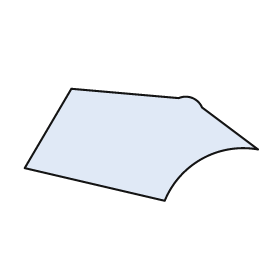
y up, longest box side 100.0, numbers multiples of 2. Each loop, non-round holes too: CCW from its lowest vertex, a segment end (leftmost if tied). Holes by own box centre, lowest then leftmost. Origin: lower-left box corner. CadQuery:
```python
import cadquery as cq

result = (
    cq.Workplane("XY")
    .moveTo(60.0, 0.0)
    .threePointArc((76.0, 18.0), (100.0, 22.0))
    .lineTo(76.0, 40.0)
    .threePointArc((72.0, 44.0), (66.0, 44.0))
    .lineTo(20.0, 48.0)
    .lineTo(0.0, 14.0)
    .close()
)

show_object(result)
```